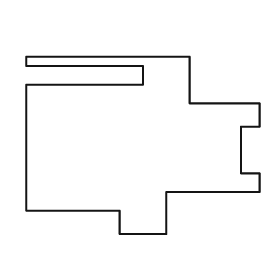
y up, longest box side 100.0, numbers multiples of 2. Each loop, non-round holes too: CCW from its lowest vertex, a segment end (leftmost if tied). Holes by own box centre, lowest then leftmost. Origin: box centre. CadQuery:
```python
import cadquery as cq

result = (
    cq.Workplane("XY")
    .moveTo(-10.0, -38.0)
    .lineTo(10.0, -38.0)
    .lineTo(10.0, -20.0)
    .lineTo(50.0, -20.0)
    .lineTo(50.0, -12.0)
    .lineTo(42.0, -12.0)
    .lineTo(42.0, 8.0)
    .lineTo(50.0, 8.0)
    .lineTo(50.0, 18.0)
    .lineTo(20.0, 18.0)
    .lineTo(20.0, 38.0)
    .lineTo(-50.0, 38.0)
    .lineTo(-50.0, 34.0)
    .lineTo(0.0, 34.0)
    .lineTo(0.0, 26.0)
    .lineTo(-50.0, 26.0)
    .lineTo(-50.0, -28.0)
    .lineTo(-10.0, -28.0)
    .close()
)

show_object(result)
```